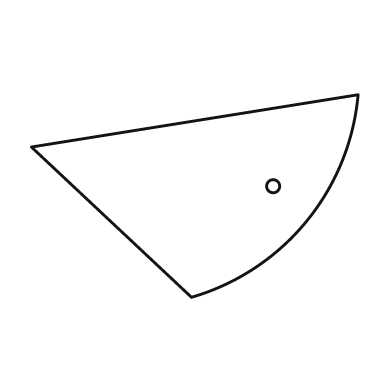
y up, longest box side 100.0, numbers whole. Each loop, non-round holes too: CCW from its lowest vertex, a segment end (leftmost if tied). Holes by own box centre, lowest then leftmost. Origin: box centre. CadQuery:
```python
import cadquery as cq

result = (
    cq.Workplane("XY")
    .moveTo(-1.0, -31.0)
    .threePointArc((34.0, -8.0), (50.0, 31.0))
    .lineTo(-50.0, 15.0)
    .close()
    .moveTo(24.0, 3.0)
    .circle(2.0)
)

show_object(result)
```